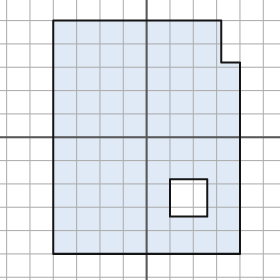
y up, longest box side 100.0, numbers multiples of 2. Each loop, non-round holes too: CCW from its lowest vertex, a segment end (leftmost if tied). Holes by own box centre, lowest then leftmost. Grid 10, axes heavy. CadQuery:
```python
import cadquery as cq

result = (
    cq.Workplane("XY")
    .moveTo(-40.0, -50.0)
    .lineTo(40.0, -50.0)
    .lineTo(40.0, 32.0)
    .lineTo(32.0, 32.0)
    .lineTo(32.0, 50.0)
    .lineTo(-40.0, 50.0)
    .close()
    .moveTo(10.0, -34.0)
    .lineTo(26.0, -34.0)
    .lineTo(26.0, -18.0)
    .lineTo(10.0, -18.0)
    .close()
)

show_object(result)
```